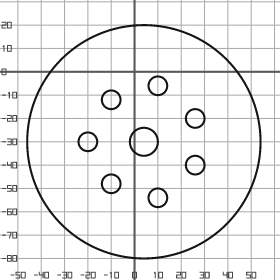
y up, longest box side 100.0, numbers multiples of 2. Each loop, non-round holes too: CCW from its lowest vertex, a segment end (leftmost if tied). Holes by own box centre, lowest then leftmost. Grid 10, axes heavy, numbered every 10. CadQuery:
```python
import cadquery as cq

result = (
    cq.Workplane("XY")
    .moveTo(4.0, -30.0)
    .circle(50.0)
    .moveTo(10.0, -54.0)
    .circle(4.0)
    .moveTo(-10.0, -48.0)
    .circle(4.0)
    .moveTo(26.0, -40.0)
    .circle(4.0)
    .moveTo(-20.0, -30.0)
    .circle(4.0)
    .moveTo(4.0, -30.0)
    .circle(6.0)
    .moveTo(26.0, -20.0)
    .circle(4.0)
    .moveTo(-10.0, -12.0)
    .circle(4.0)
    .moveTo(10.0, -6.0)
    .circle(4.0)
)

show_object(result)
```